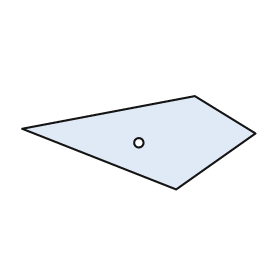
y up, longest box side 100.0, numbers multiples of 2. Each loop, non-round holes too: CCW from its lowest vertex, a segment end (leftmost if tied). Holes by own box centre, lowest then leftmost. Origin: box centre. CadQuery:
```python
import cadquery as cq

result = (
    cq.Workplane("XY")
    .moveTo(16.0, -20.0)
    .lineTo(50.0, 4.0)
    .lineTo(24.0, 20.0)
    .lineTo(-50.0, 6.0)
    .close()
    .moveTo(0.0, 0.0)
    .circle(2.0)
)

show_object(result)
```